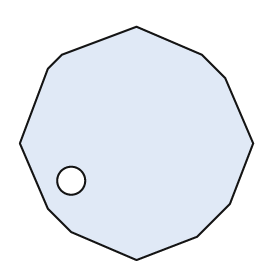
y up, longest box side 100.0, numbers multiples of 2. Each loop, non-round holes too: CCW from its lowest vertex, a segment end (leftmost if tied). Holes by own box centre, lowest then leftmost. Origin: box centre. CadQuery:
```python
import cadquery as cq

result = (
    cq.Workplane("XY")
    .moveTo(0.0, -50.0)
    .lineTo(26.0, -40.0)
    .lineTo(40.0, -26.0)
    .lineTo(50.0, 0.0)
    .lineTo(38.0, 28.0)
    .lineTo(28.0, 38.0)
    .lineTo(0.0, 50.0)
    .lineTo(-32.0, 38.0)
    .lineTo(-38.0, 32.0)
    .lineTo(-50.0, 0.0)
    .lineTo(-38.0, -28.0)
    .lineTo(-28.0, -38.0)
    .close()
    .moveTo(-28.0, -16.0)
    .circle(6.0)
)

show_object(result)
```